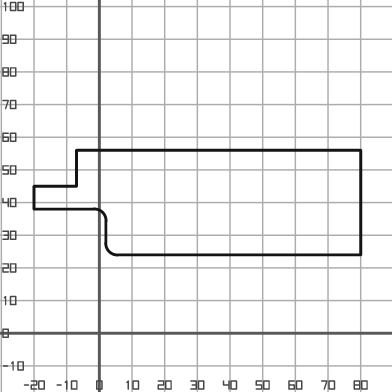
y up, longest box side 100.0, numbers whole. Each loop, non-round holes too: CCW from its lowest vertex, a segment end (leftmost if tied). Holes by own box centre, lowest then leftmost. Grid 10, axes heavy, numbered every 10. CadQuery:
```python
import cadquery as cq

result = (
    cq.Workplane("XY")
    .moveTo(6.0, 24.0)
    .lineTo(80.0, 24.0)
    .lineTo(80.0, 56.0)
    .lineTo(-7.0, 56.0)
    .lineTo(-7.0, 45.0)
    .lineTo(-20.0, 45.0)
    .lineTo(-20.0, 38.0)
    .lineTo(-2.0, 38.0)
    .threePointArc((1.0, 37.0), (2.0, 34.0))
    .lineTo(2.0, 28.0)
    .threePointArc((3.0, 25.0), (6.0, 24.0))
    .close()
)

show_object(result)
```